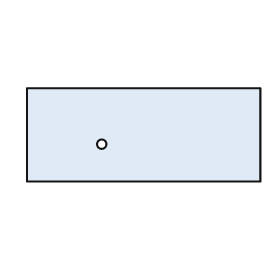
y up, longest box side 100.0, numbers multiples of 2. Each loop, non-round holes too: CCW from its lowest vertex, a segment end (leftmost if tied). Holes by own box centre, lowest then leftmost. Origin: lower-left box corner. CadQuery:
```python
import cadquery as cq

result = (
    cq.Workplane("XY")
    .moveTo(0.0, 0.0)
    .lineTo(100.0, 0.0)
    .lineTo(100.0, 40.0)
    .lineTo(0.0, 40.0)
    .close()
    .moveTo(32.0, 16.0)
    .circle(2.0)
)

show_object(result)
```